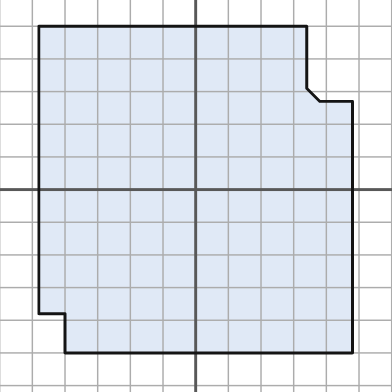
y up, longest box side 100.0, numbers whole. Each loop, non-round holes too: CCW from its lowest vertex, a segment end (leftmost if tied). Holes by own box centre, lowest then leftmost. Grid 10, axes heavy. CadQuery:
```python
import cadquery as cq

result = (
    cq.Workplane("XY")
    .moveTo(-40.0, -50.0)
    .lineTo(48.0, -50.0)
    .lineTo(48.0, 27.0)
    .lineTo(38.0, 27.0)
    .lineTo(34.0, 31.0)
    .lineTo(34.0, 50.0)
    .lineTo(-48.0, 50.0)
    .lineTo(-48.0, -38.0)
    .lineTo(-40.0, -38.0)
    .close()
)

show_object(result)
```